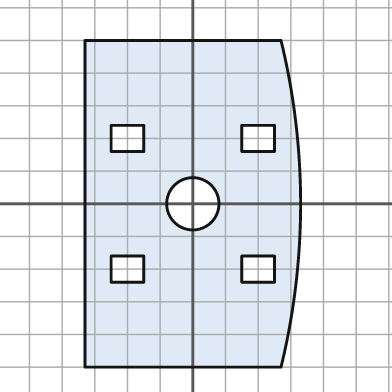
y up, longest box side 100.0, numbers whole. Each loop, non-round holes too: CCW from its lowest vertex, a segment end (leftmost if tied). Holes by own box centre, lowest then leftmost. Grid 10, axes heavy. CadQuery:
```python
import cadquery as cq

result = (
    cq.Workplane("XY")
    .moveTo(-33.0, -50.0)
    .lineTo(27.0, -50.0)
    .threePointArc((33.0, 0.0), (27.0, 50.0))
    .lineTo(-33.0, 50.0)
    .close()
    .moveTo(-25.0, -24.0)
    .lineTo(-15.0, -24.0)
    .lineTo(-15.0, -16.0)
    .lineTo(-25.0, -16.0)
    .close()
    .moveTo(15.0, -24.0)
    .lineTo(25.0, -24.0)
    .lineTo(25.0, -16.0)
    .lineTo(15.0, -16.0)
    .close()
    .moveTo(0.0, 0.0)
    .circle(8.0)
    .moveTo(-25.0, 16.0)
    .lineTo(-15.0, 16.0)
    .lineTo(-15.0, 24.0)
    .lineTo(-25.0, 24.0)
    .close()
    .moveTo(15.0, 16.0)
    .lineTo(25.0, 16.0)
    .lineTo(25.0, 24.0)
    .lineTo(15.0, 24.0)
    .close()
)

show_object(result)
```